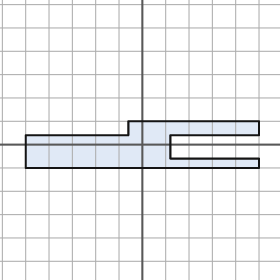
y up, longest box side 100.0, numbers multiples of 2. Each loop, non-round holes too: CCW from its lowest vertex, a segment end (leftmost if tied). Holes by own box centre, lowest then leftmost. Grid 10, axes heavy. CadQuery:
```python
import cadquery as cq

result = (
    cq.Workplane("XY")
    .moveTo(-50.0, -10.0)
    .lineTo(50.0, -10.0)
    .lineTo(50.0, -6.0)
    .lineTo(12.0, -6.0)
    .lineTo(12.0, 4.0)
    .lineTo(50.0, 4.0)
    .lineTo(50.0, 10.0)
    .lineTo(-6.0, 10.0)
    .lineTo(-6.0, 4.0)
    .lineTo(-50.0, 4.0)
    .close()
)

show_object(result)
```